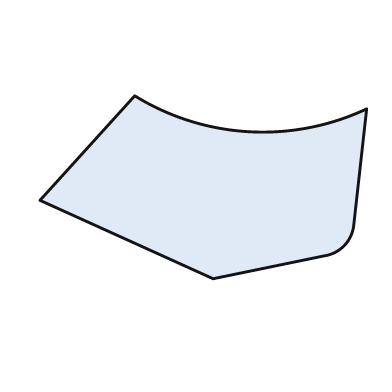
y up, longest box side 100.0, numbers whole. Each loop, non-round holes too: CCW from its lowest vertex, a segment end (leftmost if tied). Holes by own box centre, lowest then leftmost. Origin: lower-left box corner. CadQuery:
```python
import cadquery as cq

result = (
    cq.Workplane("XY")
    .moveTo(53.0, 0.0)
    .lineTo(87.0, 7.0)
    .threePointArc((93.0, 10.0), (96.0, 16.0))
    .lineTo(100.0, 52.0)
    .threePointArc((64.0, 45.0), (29.0, 56.0))
    .lineTo(0.0, 24.0)
    .close()
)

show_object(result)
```